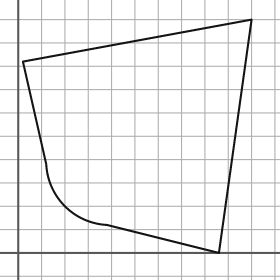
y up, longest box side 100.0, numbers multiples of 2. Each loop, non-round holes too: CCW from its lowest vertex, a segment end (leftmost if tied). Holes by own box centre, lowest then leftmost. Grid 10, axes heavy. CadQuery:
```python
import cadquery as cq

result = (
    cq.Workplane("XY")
    .moveTo(86.0, 0.0)
    .lineTo(100.0, 100.0)
    .lineTo(2.0, 82.0)
    .lineTo(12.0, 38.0)
    .threePointArc((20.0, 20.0), (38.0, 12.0))
    .close()
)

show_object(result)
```